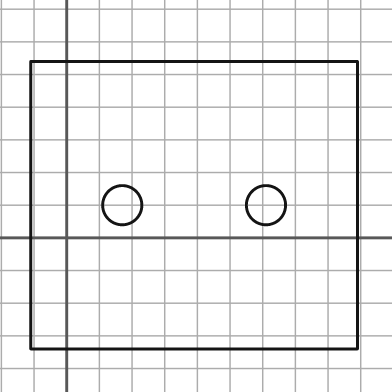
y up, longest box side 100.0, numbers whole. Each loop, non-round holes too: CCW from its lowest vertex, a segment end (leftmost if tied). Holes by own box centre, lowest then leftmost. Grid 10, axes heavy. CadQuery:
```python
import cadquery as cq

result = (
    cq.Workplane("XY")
    .moveTo(-11.0, -34.0)
    .lineTo(89.0, -34.0)
    .lineTo(89.0, 54.0)
    .lineTo(-11.0, 54.0)
    .close()
    .moveTo(17.0, 10.0)
    .circle(6.0)
    .moveTo(61.0, 10.0)
    .circle(6.0)
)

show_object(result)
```